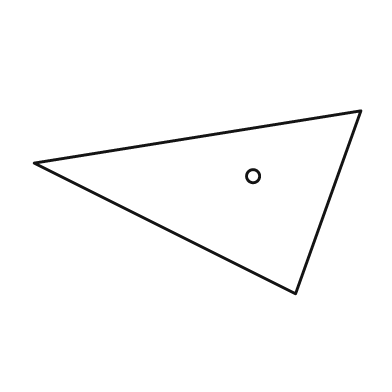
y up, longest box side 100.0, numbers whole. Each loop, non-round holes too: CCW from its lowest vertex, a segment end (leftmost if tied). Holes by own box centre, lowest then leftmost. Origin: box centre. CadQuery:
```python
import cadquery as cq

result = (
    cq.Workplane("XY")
    .moveTo(30.0, -28.0)
    .lineTo(50.0, 28.0)
    .lineTo(-50.0, 12.0)
    .close()
    .moveTo(17.0, 8.0)
    .circle(2.0)
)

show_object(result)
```